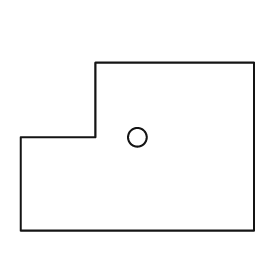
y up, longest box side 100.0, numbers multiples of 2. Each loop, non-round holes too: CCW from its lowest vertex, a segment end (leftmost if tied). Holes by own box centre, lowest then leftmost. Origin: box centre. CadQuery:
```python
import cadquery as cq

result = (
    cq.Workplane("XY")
    .moveTo(-50.0, -36.0)
    .lineTo(50.0, -36.0)
    .lineTo(50.0, 36.0)
    .lineTo(-18.0, 36.0)
    .lineTo(-18.0, 4.0)
    .lineTo(-50.0, 4.0)
    .close()
    .moveTo(0.0, 4.0)
    .circle(4.0)
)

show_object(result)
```